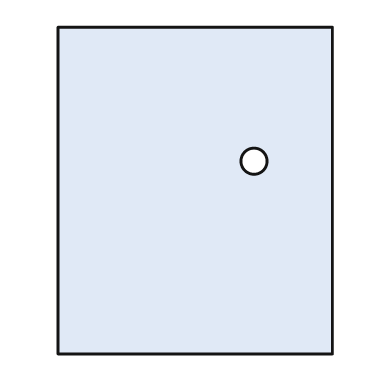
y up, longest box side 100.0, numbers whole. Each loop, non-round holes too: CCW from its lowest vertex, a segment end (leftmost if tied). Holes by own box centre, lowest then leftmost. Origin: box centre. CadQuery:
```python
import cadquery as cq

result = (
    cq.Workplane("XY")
    .moveTo(-42.0, -50.0)
    .lineTo(42.0, -50.0)
    .lineTo(42.0, 50.0)
    .lineTo(-42.0, 50.0)
    .close()
    .moveTo(18.0, 9.0)
    .circle(4.0)
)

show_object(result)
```